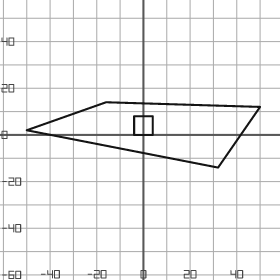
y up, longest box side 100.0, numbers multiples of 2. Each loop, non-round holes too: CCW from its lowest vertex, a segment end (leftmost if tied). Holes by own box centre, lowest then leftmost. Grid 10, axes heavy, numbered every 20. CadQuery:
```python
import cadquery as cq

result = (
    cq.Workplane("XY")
    .moveTo(32.0, -14.0)
    .lineTo(50.0, 12.0)
    .lineTo(-16.0, 14.0)
    .lineTo(-50.0, 2.0)
    .close()
    .moveTo(-4.0, 0.0)
    .lineTo(4.0, 0.0)
    .lineTo(4.0, 8.0)
    .lineTo(-4.0, 8.0)
    .close()
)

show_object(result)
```